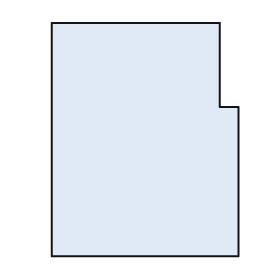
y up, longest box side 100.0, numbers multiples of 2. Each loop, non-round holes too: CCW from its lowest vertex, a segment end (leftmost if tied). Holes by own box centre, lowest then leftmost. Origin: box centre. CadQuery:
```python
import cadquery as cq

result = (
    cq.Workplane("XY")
    .moveTo(-40.0, -50.0)
    .lineTo(40.0, -50.0)
    .lineTo(40.0, 14.0)
    .lineTo(32.0, 14.0)
    .lineTo(32.0, 50.0)
    .lineTo(-40.0, 50.0)
    .close()
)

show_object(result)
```